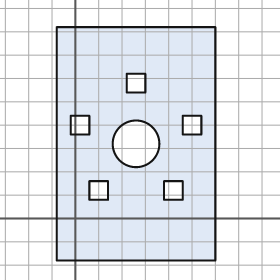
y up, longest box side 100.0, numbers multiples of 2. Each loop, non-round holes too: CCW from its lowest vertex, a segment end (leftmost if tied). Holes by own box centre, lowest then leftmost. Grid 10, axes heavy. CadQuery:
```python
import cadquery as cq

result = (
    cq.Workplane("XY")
    .moveTo(-8.0, -18.0)
    .lineTo(60.0, -18.0)
    .lineTo(60.0, 82.0)
    .lineTo(-8.0, 82.0)
    .close()
    .moveTo(6.0, 8.0)
    .lineTo(14.0, 8.0)
    .lineTo(14.0, 16.0)
    .lineTo(6.0, 16.0)
    .close()
    .moveTo(38.0, 8.0)
    .lineTo(46.0, 8.0)
    .lineTo(46.0, 16.0)
    .lineTo(38.0, 16.0)
    .close()
    .moveTo(26.0, 32.0)
    .circle(10.0)
    .moveTo(-2.0, 36.0)
    .lineTo(6.0, 36.0)
    .lineTo(6.0, 44.0)
    .lineTo(-2.0, 44.0)
    .close()
    .moveTo(46.0, 36.0)
    .lineTo(54.0, 36.0)
    .lineTo(54.0, 44.0)
    .lineTo(46.0, 44.0)
    .close()
    .moveTo(22.0, 54.0)
    .lineTo(30.0, 54.0)
    .lineTo(30.0, 62.0)
    .lineTo(22.0, 62.0)
    .close()
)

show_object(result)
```